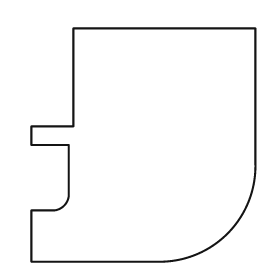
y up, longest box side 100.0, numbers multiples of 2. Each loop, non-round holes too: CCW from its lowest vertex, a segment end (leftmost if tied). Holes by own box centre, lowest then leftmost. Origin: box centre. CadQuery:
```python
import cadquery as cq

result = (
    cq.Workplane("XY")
    .moveTo(-48.0, -50.0)
    .lineTo(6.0, -50.0)
    .threePointArc((36.0, -38.0), (48.0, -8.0))
    .lineTo(48.0, 50.0)
    .lineTo(-30.0, 50.0)
    .lineTo(-30.0, 8.0)
    .lineTo(-48.0, 8.0)
    .lineTo(-48.0, 0.0)
    .lineTo(-32.0, 0.0)
    .lineTo(-32.0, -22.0)
    .threePointArc((-34.0, -26.0), (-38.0, -28.0))
    .lineTo(-48.0, -28.0)
    .close()
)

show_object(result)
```